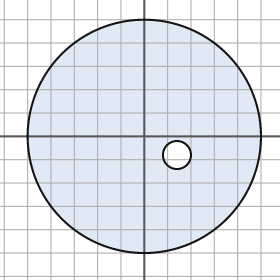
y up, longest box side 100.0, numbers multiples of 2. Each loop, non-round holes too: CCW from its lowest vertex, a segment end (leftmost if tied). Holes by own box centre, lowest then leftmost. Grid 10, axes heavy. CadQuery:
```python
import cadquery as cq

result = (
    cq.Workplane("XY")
    .moveTo(0.0, 0.0)
    .circle(50.0)
    .moveTo(14.0, -8.0)
    .circle(6.0)
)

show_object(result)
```